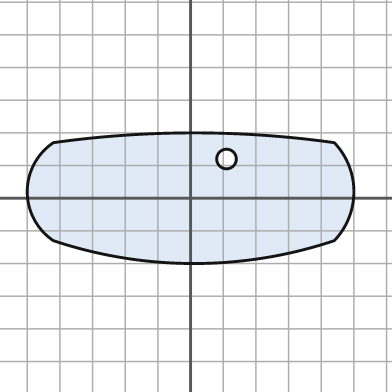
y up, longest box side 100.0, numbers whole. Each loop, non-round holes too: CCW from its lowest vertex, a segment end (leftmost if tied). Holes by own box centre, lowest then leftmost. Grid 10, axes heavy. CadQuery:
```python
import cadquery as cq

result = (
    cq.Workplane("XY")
    .moveTo(-42.0, -13.0)
    .threePointArc((1.0, -20.0), (44.0, -13.0))
    .threePointArc((50.0, 2.0), (44.0, 17.0))
    .threePointArc((1.0, 20.0), (-42.0, 17.0))
    .threePointArc((-50.0, 2.0), (-42.0, -13.0))
    .close()
    .moveTo(11.0, 12.0)
    .circle(3.0)
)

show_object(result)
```